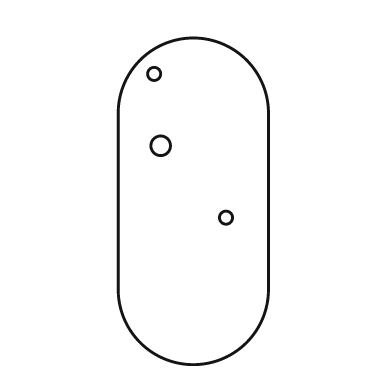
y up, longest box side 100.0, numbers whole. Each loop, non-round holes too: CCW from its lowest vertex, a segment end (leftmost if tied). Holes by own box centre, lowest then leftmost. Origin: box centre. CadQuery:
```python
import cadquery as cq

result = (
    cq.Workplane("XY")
    .moveTo(-23.0, -27.0)
    .threePointArc((0.0, -50.0), (23.0, -27.0))
    .lineTo(23.0, 27.0)
    .threePointArc((0.0, 50.0), (-23.0, 27.0))
    .close()
    .moveTo(10.0, -5.0)
    .circle(2.0)
    .moveTo(-10.0, 17.0)
    .circle(3.0)
    .moveTo(-12.0, 39.0)
    .circle(2.0)
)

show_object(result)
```